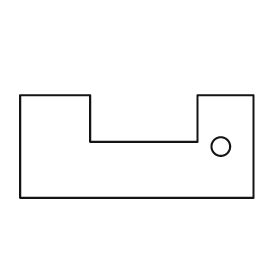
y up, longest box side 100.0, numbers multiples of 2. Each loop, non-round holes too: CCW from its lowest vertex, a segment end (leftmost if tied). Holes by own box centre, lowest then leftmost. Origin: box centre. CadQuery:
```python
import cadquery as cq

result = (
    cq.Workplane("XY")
    .moveTo(-50.0, -22.0)
    .lineTo(50.0, -22.0)
    .lineTo(50.0, 22.0)
    .lineTo(26.0, 22.0)
    .lineTo(26.0, 2.0)
    .lineTo(-20.0, 2.0)
    .lineTo(-20.0, 22.0)
    .lineTo(-50.0, 22.0)
    .close()
    .moveTo(36.0, 0.0)
    .circle(4.0)
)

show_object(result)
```